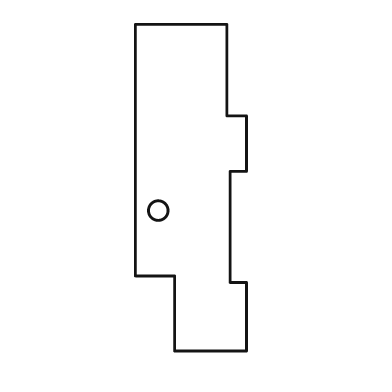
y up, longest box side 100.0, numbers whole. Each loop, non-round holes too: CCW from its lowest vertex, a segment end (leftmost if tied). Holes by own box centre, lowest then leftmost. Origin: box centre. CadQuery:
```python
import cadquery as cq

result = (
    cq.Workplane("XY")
    .moveTo(-5.0, -50.0)
    .lineTo(17.0, -50.0)
    .lineTo(17.0, -29.0)
    .lineTo(12.0, -29.0)
    .lineTo(12.0, 5.0)
    .lineTo(17.0, 5.0)
    .lineTo(17.0, 22.0)
    .lineTo(11.0, 22.0)
    .lineTo(11.0, 50.0)
    .lineTo(-17.0, 50.0)
    .lineTo(-17.0, -27.0)
    .lineTo(-5.0, -27.0)
    .close()
    .moveTo(-10.0, -7.0)
    .circle(3.0)
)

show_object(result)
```